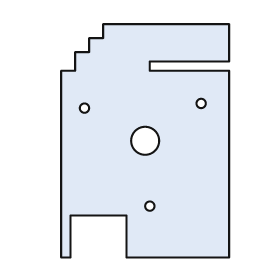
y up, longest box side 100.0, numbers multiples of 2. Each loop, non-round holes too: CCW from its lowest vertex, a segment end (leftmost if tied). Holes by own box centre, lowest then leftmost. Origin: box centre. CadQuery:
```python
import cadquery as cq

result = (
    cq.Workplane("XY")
    .moveTo(-36.0, -50.0)
    .lineTo(-32.0, -50.0)
    .lineTo(-32.0, -32.0)
    .lineTo(-8.0, -32.0)
    .lineTo(-8.0, -50.0)
    .lineTo(36.0, -50.0)
    .lineTo(36.0, 30.0)
    .lineTo(2.0, 30.0)
    .lineTo(2.0, 34.0)
    .lineTo(36.0, 34.0)
    .lineTo(36.0, 50.0)
    .lineTo(-18.0, 50.0)
    .lineTo(-18.0, 44.0)
    .lineTo(-24.0, 44.0)
    .lineTo(-24.0, 38.0)
    .lineTo(-30.0, 38.0)
    .lineTo(-30.0, 30.0)
    .lineTo(-36.0, 30.0)
    .close()
    .moveTo(2.0, -28.0)
    .circle(2.0)
    .moveTo(0.0, 0.0)
    .circle(6.0)
    .moveTo(-26.0, 14.0)
    .circle(2.0)
    .moveTo(24.0, 16.0)
    .circle(2.0)
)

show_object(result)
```